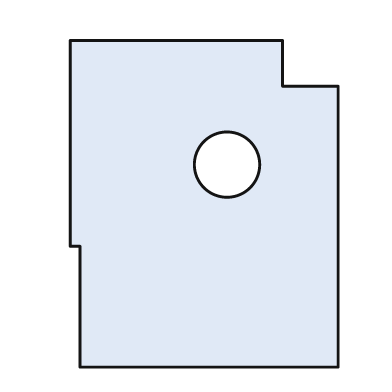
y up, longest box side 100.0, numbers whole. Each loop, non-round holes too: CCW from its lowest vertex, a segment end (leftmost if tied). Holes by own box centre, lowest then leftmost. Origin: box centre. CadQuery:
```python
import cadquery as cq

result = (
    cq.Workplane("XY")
    .moveTo(-38.0, -50.0)
    .lineTo(41.0, -50.0)
    .lineTo(41.0, 36.0)
    .lineTo(24.0, 36.0)
    .lineTo(24.0, 50.0)
    .lineTo(-41.0, 50.0)
    .lineTo(-41.0, -13.0)
    .lineTo(-38.0, -13.0)
    .close()
    .moveTo(7.0, 12.0)
    .circle(10.0)
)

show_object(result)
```